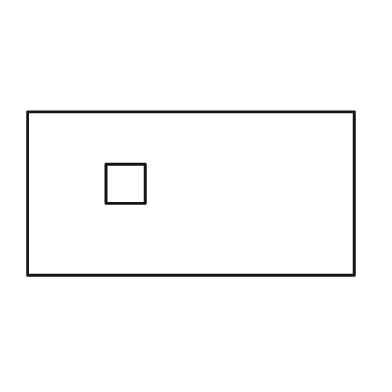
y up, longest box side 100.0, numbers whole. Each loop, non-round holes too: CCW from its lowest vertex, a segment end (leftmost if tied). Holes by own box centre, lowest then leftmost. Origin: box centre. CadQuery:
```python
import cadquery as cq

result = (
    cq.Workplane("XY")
    .moveTo(-50.0, -25.0)
    .lineTo(50.0, -25.0)
    .lineTo(50.0, 25.0)
    .lineTo(-50.0, 25.0)
    .close()
    .moveTo(-26.0, -3.0)
    .lineTo(-14.0, -3.0)
    .lineTo(-14.0, 9.0)
    .lineTo(-26.0, 9.0)
    .close()
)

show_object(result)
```